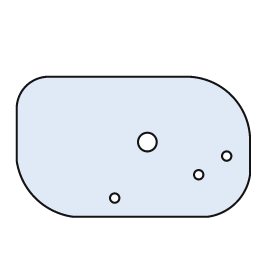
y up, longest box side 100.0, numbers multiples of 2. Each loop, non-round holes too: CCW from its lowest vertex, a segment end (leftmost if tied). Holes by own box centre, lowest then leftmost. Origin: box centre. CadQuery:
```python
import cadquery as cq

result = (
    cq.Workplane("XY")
    .moveTo(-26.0, -30.0)
    .lineTo(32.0, -30.0)
    .threePointArc((44.0, -24.0), (50.0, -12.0))
    .lineTo(50.0, 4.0)
    .threePointArc((42.0, 22.0), (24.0, 30.0))
    .lineTo(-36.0, 30.0)
    .threePointArc((-46.0, 26.0), (-50.0, 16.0))
    .lineTo(-50.0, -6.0)
    .threePointArc((-42.0, -22.0), (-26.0, -30.0))
    .close()
    .moveTo(-8.0, -22.0)
    .circle(2.0)
    .moveTo(28.0, -12.0)
    .circle(2.0)
    .moveTo(40.0, -4.0)
    .circle(2.0)
    .moveTo(6.0, 2.0)
    .circle(4.0)
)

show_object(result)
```